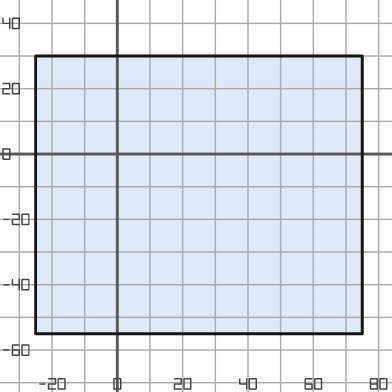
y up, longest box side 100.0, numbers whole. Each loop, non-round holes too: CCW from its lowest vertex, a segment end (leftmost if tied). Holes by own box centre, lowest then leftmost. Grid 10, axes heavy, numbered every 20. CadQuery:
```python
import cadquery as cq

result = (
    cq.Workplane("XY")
    .moveTo(-25.0, -55.0)
    .lineTo(75.0, -55.0)
    .lineTo(75.0, 30.0)
    .lineTo(-25.0, 30.0)
    .close()
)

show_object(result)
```